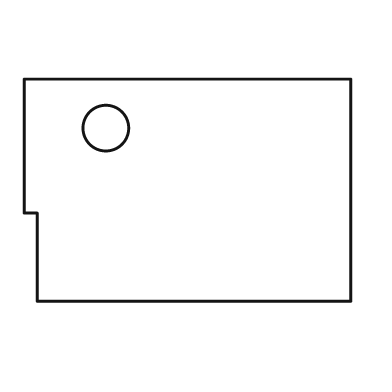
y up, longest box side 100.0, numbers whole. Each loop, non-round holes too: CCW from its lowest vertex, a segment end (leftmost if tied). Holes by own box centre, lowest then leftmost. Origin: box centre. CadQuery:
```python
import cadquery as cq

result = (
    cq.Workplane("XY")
    .moveTo(-46.0, -34.0)
    .lineTo(50.0, -34.0)
    .lineTo(50.0, 34.0)
    .lineTo(-50.0, 34.0)
    .lineTo(-50.0, -7.0)
    .lineTo(-46.0, -7.0)
    .close()
    .moveTo(-25.0, 19.0)
    .circle(7.0)
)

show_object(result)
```